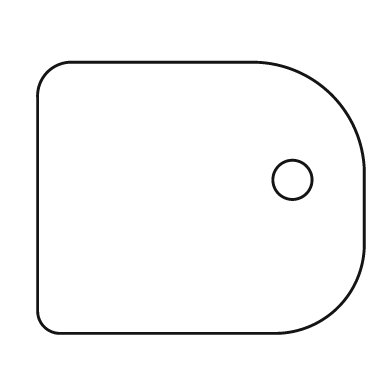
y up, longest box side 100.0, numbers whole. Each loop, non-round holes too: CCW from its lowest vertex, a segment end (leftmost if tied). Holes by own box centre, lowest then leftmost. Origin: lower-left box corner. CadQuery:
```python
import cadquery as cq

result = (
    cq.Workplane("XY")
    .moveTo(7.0, 0.0)
    .lineTo(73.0, 0.0)
    .threePointArc((92.0, 8.0), (100.0, 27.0))
    .lineTo(100.0, 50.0)
    .threePointArc((90.0, 73.0), (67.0, 83.0))
    .lineTo(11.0, 83.0)
    .threePointArc((3.0, 80.0), (0.0, 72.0))
    .lineTo(0.0, 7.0)
    .threePointArc((2.0, 2.0), (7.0, 0.0))
    .close()
    .moveTo(78.0, 47.0)
    .circle(6.0)
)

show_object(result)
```